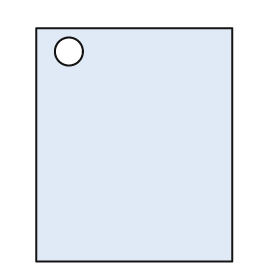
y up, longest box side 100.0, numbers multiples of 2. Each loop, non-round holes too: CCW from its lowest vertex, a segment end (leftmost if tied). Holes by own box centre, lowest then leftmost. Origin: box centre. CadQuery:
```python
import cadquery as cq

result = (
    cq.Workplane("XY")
    .moveTo(-42.0, -50.0)
    .lineTo(42.0, -50.0)
    .lineTo(42.0, 50.0)
    .lineTo(-42.0, 50.0)
    .close()
    .moveTo(-28.0, 40.0)
    .circle(6.0)
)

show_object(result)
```